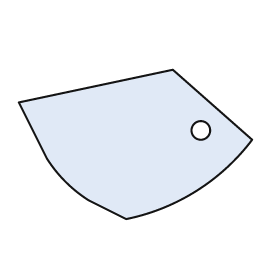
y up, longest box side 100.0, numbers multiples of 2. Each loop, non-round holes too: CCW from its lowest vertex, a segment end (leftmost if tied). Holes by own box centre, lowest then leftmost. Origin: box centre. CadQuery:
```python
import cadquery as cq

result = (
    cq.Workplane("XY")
    .moveTo(-4.0, -32.0)
    .threePointArc((26.0, -20.0), (50.0, 2.0))
    .lineTo(16.0, 32.0)
    .lineTo(-50.0, 18.0)
    .lineTo(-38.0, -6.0)
    .threePointArc((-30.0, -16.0), (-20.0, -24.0))
    .close()
    .moveTo(28.0, 6.0)
    .circle(4.0)
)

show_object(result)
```